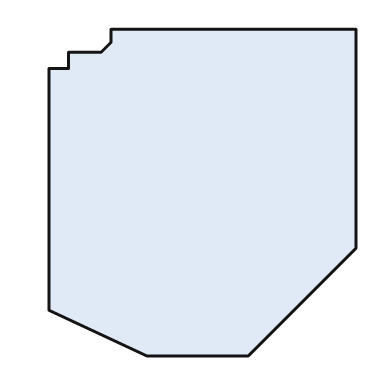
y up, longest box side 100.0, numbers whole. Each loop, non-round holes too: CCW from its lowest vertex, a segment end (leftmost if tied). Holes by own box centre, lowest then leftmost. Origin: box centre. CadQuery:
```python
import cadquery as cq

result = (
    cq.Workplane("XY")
    .moveTo(-17.0, -50.0)
    .lineTo(14.0, -50.0)
    .lineTo(47.0, -17.0)
    .lineTo(47.0, 50.0)
    .lineTo(-28.0, 50.0)
    .lineTo(-28.0, 46.0)
    .lineTo(-31.0, 43.0)
    .lineTo(-41.0, 43.0)
    .lineTo(-41.0, 38.0)
    .lineTo(-47.0, 38.0)
    .lineTo(-47.0, -36.0)
    .close()
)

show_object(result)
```